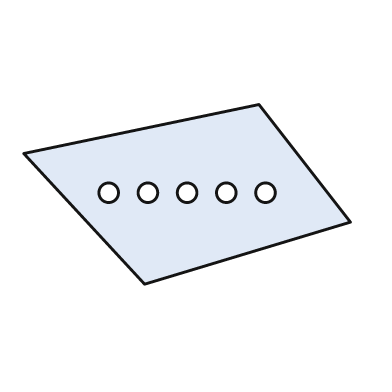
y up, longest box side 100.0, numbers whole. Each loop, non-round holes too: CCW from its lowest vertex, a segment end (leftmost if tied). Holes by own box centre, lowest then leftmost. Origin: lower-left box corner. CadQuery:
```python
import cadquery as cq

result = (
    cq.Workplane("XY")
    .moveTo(37.0, 0.0)
    .lineTo(100.0, 19.0)
    .lineTo(72.0, 55.0)
    .lineTo(0.0, 40.0)
    .close()
    .moveTo(26.0, 28.0)
    .circle(3.0)
    .moveTo(38.0, 28.0)
    .circle(3.0)
    .moveTo(50.0, 28.0)
    .circle(3.0)
    .moveTo(62.0, 28.0)
    .circle(3.0)
    .moveTo(74.0, 28.0)
    .circle(3.0)
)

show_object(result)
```